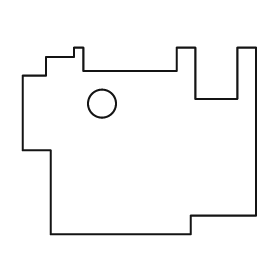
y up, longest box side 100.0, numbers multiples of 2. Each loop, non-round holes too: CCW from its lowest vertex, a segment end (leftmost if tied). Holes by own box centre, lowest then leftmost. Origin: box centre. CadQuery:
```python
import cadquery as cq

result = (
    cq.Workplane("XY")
    .moveTo(-38.0, -40.0)
    .lineTo(22.0, -40.0)
    .lineTo(22.0, -32.0)
    .lineTo(50.0, -32.0)
    .lineTo(50.0, 40.0)
    .lineTo(42.0, 40.0)
    .lineTo(42.0, 18.0)
    .lineTo(24.0, 18.0)
    .lineTo(24.0, 40.0)
    .lineTo(16.0, 40.0)
    .lineTo(16.0, 30.0)
    .lineTo(-24.0, 30.0)
    .lineTo(-24.0, 40.0)
    .lineTo(-28.0, 40.0)
    .lineTo(-28.0, 36.0)
    .lineTo(-40.0, 36.0)
    .lineTo(-40.0, 28.0)
    .lineTo(-50.0, 28.0)
    .lineTo(-50.0, -4.0)
    .lineTo(-38.0, -4.0)
    .close()
    .moveTo(-16.0, 16.0)
    .circle(6.0)
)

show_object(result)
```